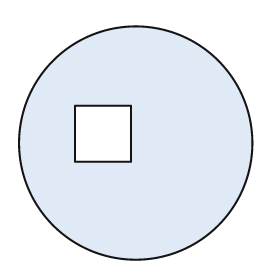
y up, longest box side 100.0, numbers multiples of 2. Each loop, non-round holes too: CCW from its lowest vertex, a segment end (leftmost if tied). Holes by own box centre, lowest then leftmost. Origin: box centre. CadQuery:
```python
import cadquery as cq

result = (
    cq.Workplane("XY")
    .moveTo(0.0, 0.0)
    .circle(50.0)
    .moveTo(-26.0, -8.0)
    .lineTo(-2.0, -8.0)
    .lineTo(-2.0, 16.0)
    .lineTo(-26.0, 16.0)
    .close()
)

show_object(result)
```